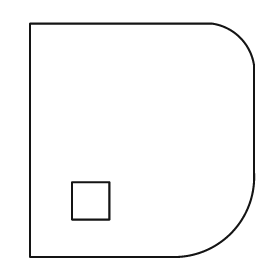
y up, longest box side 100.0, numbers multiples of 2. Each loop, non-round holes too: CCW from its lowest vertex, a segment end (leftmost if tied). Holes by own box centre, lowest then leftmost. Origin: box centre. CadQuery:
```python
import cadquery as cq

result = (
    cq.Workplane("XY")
    .moveTo(-48.0, -50.0)
    .lineTo(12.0, -50.0)
    .threePointArc((38.0, -40.0), (48.0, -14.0))
    .lineTo(48.0, 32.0)
    .threePointArc((42.0, 44.0), (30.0, 50.0))
    .lineTo(-48.0, 50.0)
    .close()
    .moveTo(-30.0, -34.0)
    .lineTo(-14.0, -34.0)
    .lineTo(-14.0, -18.0)
    .lineTo(-30.0, -18.0)
    .close()
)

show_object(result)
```